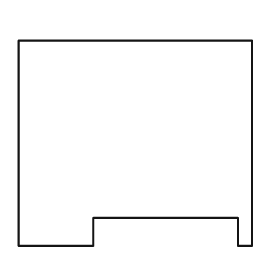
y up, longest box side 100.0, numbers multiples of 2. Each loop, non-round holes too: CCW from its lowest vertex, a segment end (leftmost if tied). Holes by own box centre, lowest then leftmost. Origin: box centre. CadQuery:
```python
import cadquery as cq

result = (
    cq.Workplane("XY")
    .moveTo(-50.0, -44.0)
    .lineTo(-18.0, -44.0)
    .lineTo(-18.0, -32.0)
    .lineTo(44.0, -32.0)
    .lineTo(44.0, -44.0)
    .lineTo(50.0, -44.0)
    .lineTo(50.0, 44.0)
    .lineTo(-50.0, 44.0)
    .close()
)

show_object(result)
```